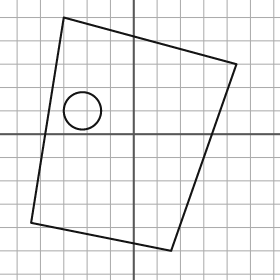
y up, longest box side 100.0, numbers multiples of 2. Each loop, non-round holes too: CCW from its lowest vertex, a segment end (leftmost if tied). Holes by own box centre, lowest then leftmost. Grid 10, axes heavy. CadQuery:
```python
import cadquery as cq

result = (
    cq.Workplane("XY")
    .moveTo(16.0, -50.0)
    .lineTo(44.0, 30.0)
    .lineTo(-30.0, 50.0)
    .lineTo(-44.0, -38.0)
    .close()
    .moveTo(-22.0, 10.0)
    .circle(8.0)
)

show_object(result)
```